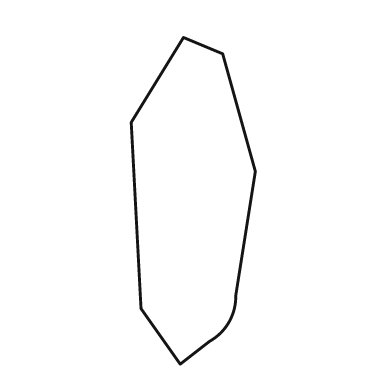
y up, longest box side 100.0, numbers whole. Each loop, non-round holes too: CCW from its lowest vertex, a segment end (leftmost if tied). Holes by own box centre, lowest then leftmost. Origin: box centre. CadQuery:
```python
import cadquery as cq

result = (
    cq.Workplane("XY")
    .moveTo(-4.0, -50.0)
    .lineTo(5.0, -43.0)
    .threePointArc((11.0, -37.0), (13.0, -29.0))
    .lineTo(19.0, 9.0)
    .lineTo(9.0, 45.0)
    .lineTo(-3.0, 50.0)
    .lineTo(-19.0, 24.0)
    .lineTo(-16.0, -33.0)
    .close()
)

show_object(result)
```